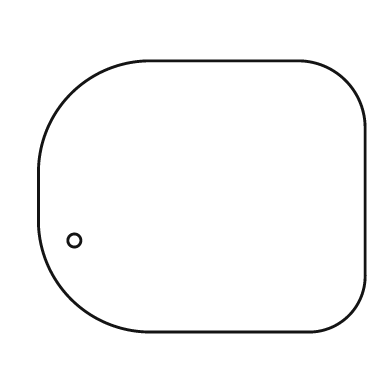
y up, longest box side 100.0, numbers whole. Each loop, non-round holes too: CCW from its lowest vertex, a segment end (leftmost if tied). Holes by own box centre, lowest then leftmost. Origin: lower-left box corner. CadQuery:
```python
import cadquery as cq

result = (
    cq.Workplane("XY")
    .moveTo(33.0, 0.0)
    .lineTo(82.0, 0.0)
    .threePointArc((95.0, 5.0), (100.0, 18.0))
    .lineTo(100.0, 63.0)
    .threePointArc((94.0, 77.0), (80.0, 83.0))
    .lineTo(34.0, 83.0)
    .threePointArc((10.0, 73.0), (0.0, 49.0))
    .lineTo(0.0, 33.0)
    .threePointArc((10.0, 10.0), (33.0, 0.0))
    .close()
    .moveTo(11.0, 28.0)
    .circle(2.0)
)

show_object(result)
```